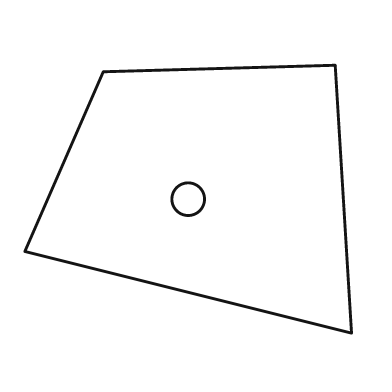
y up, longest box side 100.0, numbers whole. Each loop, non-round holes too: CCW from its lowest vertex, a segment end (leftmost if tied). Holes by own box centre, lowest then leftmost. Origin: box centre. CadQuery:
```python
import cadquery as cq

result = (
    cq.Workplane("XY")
    .moveTo(50.0, -41.0)
    .lineTo(45.0, 41.0)
    .lineTo(-26.0, 39.0)
    .lineTo(-50.0, -16.0)
    .close()
    .moveTo(0.0, 0.0)
    .circle(5.0)
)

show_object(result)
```